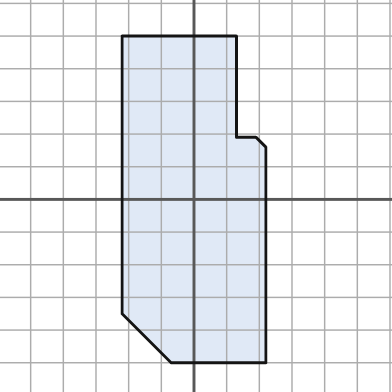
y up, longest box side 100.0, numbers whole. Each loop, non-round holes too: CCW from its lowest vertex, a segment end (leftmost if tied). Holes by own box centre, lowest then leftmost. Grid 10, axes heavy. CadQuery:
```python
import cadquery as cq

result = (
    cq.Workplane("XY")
    .moveTo(-7.0, -50.0)
    .lineTo(22.0, -50.0)
    .lineTo(22.0, 16.0)
    .lineTo(19.0, 19.0)
    .lineTo(13.0, 19.0)
    .lineTo(13.0, 50.0)
    .lineTo(-22.0, 50.0)
    .lineTo(-22.0, -35.0)
    .close()
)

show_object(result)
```